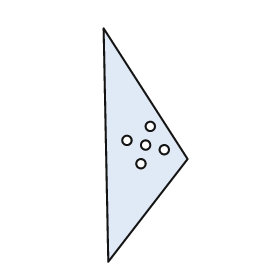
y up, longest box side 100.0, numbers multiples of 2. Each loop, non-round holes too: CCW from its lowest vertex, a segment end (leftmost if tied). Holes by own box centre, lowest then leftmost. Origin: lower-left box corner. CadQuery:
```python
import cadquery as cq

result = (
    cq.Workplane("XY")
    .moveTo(2.0, 0.0)
    .lineTo(36.0, 44.0)
    .lineTo(0.0, 100.0)
    .close()
    .moveTo(16.0, 42.0)
    .circle(2.0)
    .moveTo(26.0, 48.0)
    .circle(2.0)
    .moveTo(18.0, 50.0)
    .circle(2.0)
    .moveTo(10.0, 52.0)
    .circle(2.0)
    .moveTo(20.0, 58.0)
    .circle(2.0)
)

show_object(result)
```